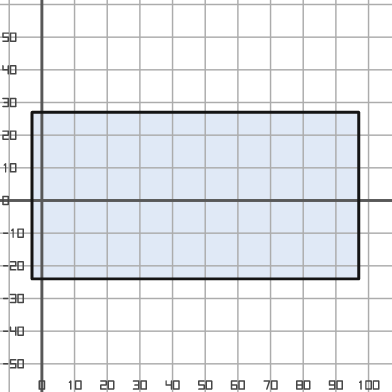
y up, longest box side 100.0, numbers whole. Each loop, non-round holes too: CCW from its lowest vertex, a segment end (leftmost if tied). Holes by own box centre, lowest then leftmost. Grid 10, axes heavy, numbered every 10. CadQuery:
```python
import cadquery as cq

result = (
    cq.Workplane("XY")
    .moveTo(-3.0, -24.0)
    .lineTo(97.0, -24.0)
    .lineTo(97.0, 27.0)
    .lineTo(-3.0, 27.0)
    .close()
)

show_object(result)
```